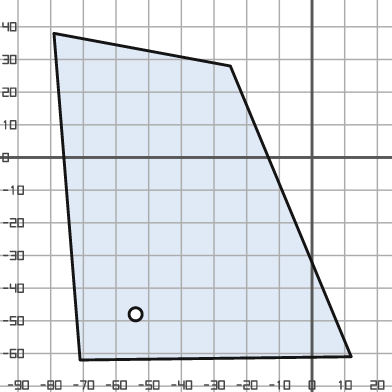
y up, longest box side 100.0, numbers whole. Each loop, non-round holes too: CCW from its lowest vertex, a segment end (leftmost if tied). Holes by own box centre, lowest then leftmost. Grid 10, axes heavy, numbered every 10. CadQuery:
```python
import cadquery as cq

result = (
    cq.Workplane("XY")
    .moveTo(-71.0, -62.0)
    .lineTo(12.0, -61.0)
    .lineTo(-25.0, 28.0)
    .lineTo(-79.0, 38.0)
    .close()
    .moveTo(-54.0, -48.0)
    .circle(2.0)
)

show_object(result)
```